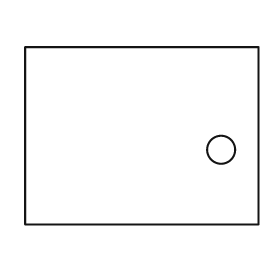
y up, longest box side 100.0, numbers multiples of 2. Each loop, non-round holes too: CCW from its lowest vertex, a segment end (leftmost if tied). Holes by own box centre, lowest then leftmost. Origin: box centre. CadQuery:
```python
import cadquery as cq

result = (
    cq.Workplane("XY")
    .moveTo(-50.0, -38.0)
    .lineTo(50.0, -38.0)
    .lineTo(50.0, 38.0)
    .lineTo(-50.0, 38.0)
    .close()
    .moveTo(34.0, -6.0)
    .circle(6.0)
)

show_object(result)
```